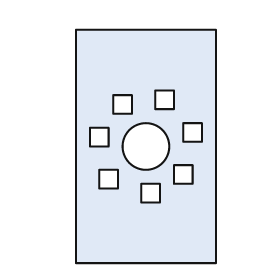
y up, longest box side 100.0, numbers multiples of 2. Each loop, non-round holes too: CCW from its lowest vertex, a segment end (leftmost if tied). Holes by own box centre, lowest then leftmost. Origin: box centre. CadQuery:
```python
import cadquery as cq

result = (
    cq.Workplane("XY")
    .moveTo(-30.0, -50.0)
    .lineTo(30.0, -50.0)
    .lineTo(30.0, 50.0)
    .lineTo(-30.0, 50.0)
    .close()
    .moveTo(-2.0, -24.0)
    .lineTo(6.0, -24.0)
    .lineTo(6.0, -16.0)
    .lineTo(-2.0, -16.0)
    .close()
    .moveTo(-20.0, -18.0)
    .lineTo(-12.0, -18.0)
    .lineTo(-12.0, -10.0)
    .lineTo(-20.0, -10.0)
    .close()
    .moveTo(12.0, -16.0)
    .lineTo(20.0, -16.0)
    .lineTo(20.0, -8.0)
    .lineTo(12.0, -8.0)
    .close()
    .moveTo(0.0, 0.0)
    .circle(10.0)
    .moveTo(-24.0, 0.0)
    .lineTo(-16.0, 0.0)
    .lineTo(-16.0, 8.0)
    .lineTo(-24.0, 8.0)
    .close()
    .moveTo(16.0, 2.0)
    .lineTo(24.0, 2.0)
    .lineTo(24.0, 10.0)
    .lineTo(16.0, 10.0)
    .close()
    .moveTo(-14.0, 14.0)
    .lineTo(-6.0, 14.0)
    .lineTo(-6.0, 22.0)
    .lineTo(-14.0, 22.0)
    .close()
    .moveTo(4.0, 16.0)
    .lineTo(12.0, 16.0)
    .lineTo(12.0, 24.0)
    .lineTo(4.0, 24.0)
    .close()
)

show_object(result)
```